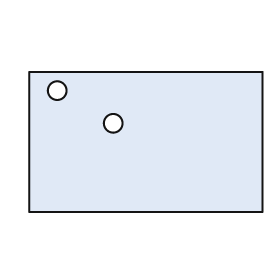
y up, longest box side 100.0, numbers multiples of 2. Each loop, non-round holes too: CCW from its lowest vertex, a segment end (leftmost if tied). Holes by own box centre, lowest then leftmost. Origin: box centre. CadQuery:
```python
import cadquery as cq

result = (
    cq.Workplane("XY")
    .moveTo(-50.0, -30.0)
    .lineTo(50.0, -30.0)
    .lineTo(50.0, 30.0)
    .lineTo(-50.0, 30.0)
    .close()
    .moveTo(-14.0, 8.0)
    .circle(4.0)
    .moveTo(-38.0, 22.0)
    .circle(4.0)
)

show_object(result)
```